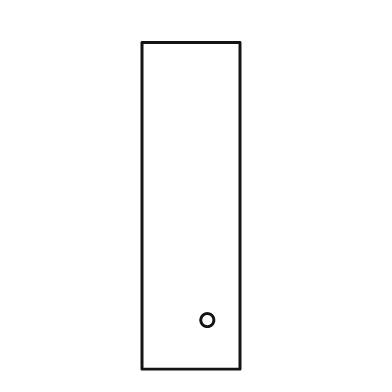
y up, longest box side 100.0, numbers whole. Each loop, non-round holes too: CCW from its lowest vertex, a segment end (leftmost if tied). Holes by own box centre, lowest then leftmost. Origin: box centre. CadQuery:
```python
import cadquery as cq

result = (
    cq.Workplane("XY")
    .moveTo(-15.0, -50.0)
    .lineTo(15.0, -50.0)
    .lineTo(15.0, 50.0)
    .lineTo(-15.0, 50.0)
    .close()
    .moveTo(5.0, -35.0)
    .circle(2.0)
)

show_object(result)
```